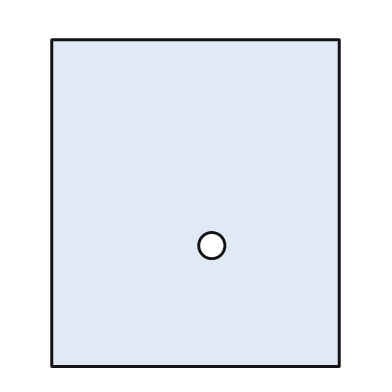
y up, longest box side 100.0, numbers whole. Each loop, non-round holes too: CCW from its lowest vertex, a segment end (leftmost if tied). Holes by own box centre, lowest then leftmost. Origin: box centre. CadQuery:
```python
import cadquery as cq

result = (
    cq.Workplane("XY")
    .moveTo(-44.0, -50.0)
    .lineTo(44.0, -50.0)
    .lineTo(44.0, 50.0)
    .lineTo(-44.0, 50.0)
    .close()
    .moveTo(5.0, -13.0)
    .circle(4.0)
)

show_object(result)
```